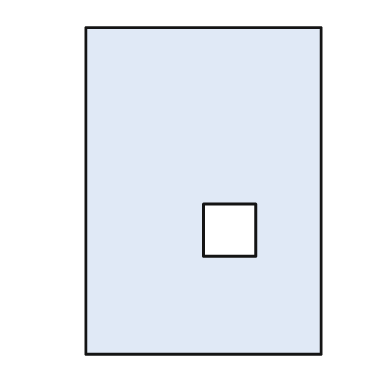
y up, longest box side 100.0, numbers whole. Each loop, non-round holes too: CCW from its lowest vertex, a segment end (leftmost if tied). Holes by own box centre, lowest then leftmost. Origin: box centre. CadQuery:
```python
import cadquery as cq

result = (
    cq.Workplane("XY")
    .moveTo(-36.0, -50.0)
    .lineTo(36.0, -50.0)
    .lineTo(36.0, 50.0)
    .lineTo(-36.0, 50.0)
    .close()
    .moveTo(0.0, -20.0)
    .lineTo(16.0, -20.0)
    .lineTo(16.0, -4.0)
    .lineTo(0.0, -4.0)
    .close()
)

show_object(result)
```